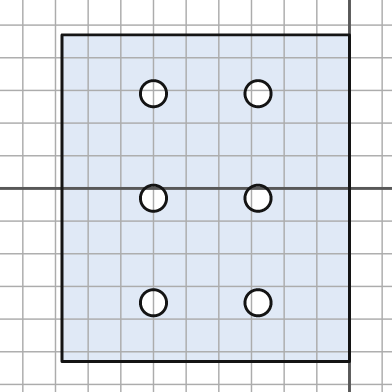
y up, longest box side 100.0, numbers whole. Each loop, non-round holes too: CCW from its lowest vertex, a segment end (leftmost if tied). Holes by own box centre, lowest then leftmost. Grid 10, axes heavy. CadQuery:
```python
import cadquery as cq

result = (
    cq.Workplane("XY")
    .moveTo(-88.0, -53.0)
    .lineTo(0.0, -53.0)
    .lineTo(0.0, 47.0)
    .lineTo(-88.0, 47.0)
    .close()
    .moveTo(-60.0, -35.0)
    .circle(4.0)
    .moveTo(-28.0, -35.0)
    .circle(4.0)
    .moveTo(-60.0, -3.0)
    .circle(4.0)
    .moveTo(-28.0, -3.0)
    .circle(4.0)
    .moveTo(-60.0, 29.0)
    .circle(4.0)
    .moveTo(-28.0, 29.0)
    .circle(4.0)
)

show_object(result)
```